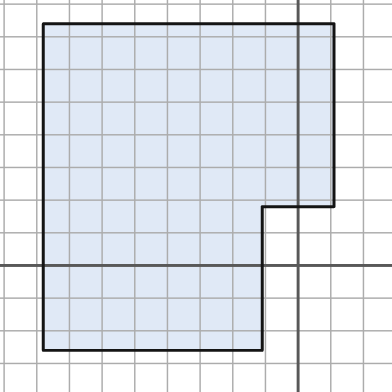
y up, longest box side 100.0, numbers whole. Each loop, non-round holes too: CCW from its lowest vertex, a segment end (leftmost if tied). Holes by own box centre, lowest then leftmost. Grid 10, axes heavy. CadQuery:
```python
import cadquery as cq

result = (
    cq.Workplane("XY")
    .moveTo(-78.0, -26.0)
    .lineTo(-11.0, -26.0)
    .lineTo(-11.0, 18.0)
    .lineTo(11.0, 18.0)
    .lineTo(11.0, 74.0)
    .lineTo(-78.0, 74.0)
    .close()
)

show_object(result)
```